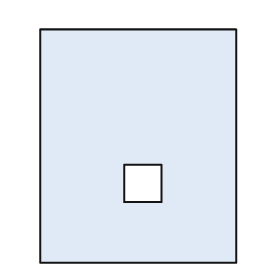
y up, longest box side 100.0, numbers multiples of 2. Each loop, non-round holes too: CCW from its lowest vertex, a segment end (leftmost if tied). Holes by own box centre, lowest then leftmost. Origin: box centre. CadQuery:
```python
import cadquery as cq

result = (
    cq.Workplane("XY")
    .moveTo(-42.0, -50.0)
    .lineTo(42.0, -50.0)
    .lineTo(42.0, 50.0)
    .lineTo(-42.0, 50.0)
    .close()
    .moveTo(-6.0, -24.0)
    .lineTo(10.0, -24.0)
    .lineTo(10.0, -8.0)
    .lineTo(-6.0, -8.0)
    .close()
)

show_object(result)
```